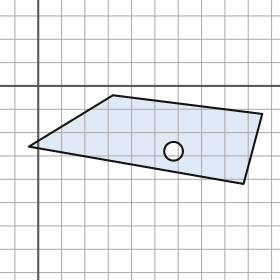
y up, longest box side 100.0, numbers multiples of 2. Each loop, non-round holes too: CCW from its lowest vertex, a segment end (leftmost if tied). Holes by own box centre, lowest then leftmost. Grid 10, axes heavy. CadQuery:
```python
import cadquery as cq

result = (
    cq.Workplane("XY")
    .moveTo(88.0, -42.0)
    .lineTo(96.0, -12.0)
    .lineTo(32.0, -4.0)
    .lineTo(-4.0, -26.0)
    .close()
    .moveTo(58.0, -28.0)
    .circle(4.0)
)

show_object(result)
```